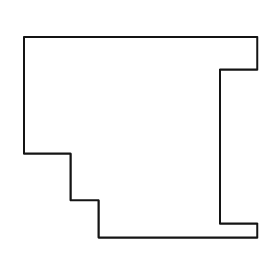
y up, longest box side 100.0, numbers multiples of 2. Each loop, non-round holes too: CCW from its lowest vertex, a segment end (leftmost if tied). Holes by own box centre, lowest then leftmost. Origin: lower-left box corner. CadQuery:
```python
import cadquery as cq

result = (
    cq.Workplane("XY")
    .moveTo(32.0, 0.0)
    .lineTo(100.0, 0.0)
    .lineTo(100.0, 6.0)
    .lineTo(84.0, 6.0)
    .lineTo(84.0, 72.0)
    .lineTo(100.0, 72.0)
    .lineTo(100.0, 86.0)
    .lineTo(0.0, 86.0)
    .lineTo(0.0, 36.0)
    .lineTo(20.0, 36.0)
    .lineTo(20.0, 16.0)
    .lineTo(32.0, 16.0)
    .close()
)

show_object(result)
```